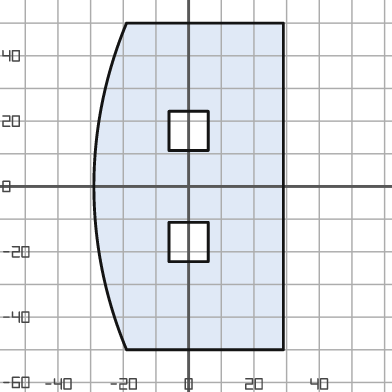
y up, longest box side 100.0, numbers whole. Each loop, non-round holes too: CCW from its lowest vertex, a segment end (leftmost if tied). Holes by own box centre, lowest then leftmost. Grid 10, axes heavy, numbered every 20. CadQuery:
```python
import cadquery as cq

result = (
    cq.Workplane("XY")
    .moveTo(-19.0, -50.0)
    .lineTo(29.0, -50.0)
    .lineTo(29.0, 50.0)
    .lineTo(-19.0, 50.0)
    .threePointArc((-29.0, 0.0), (-19.0, -50.0))
    .close()
    .moveTo(-6.0, -23.0)
    .lineTo(6.0, -23.0)
    .lineTo(6.0, -11.0)
    .lineTo(-6.0, -11.0)
    .close()
    .moveTo(-6.0, 11.0)
    .lineTo(6.0, 11.0)
    .lineTo(6.0, 23.0)
    .lineTo(-6.0, 23.0)
    .close()
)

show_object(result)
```